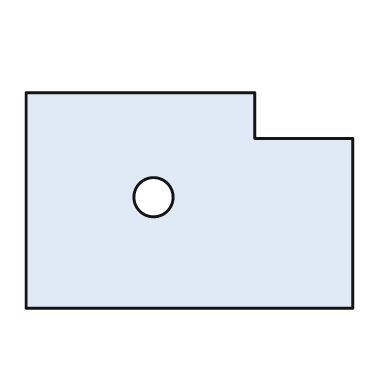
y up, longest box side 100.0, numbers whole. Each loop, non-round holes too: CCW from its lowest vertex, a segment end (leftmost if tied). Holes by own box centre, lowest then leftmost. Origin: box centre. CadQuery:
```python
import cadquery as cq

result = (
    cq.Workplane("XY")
    .moveTo(-50.0, -33.0)
    .lineTo(50.0, -33.0)
    .lineTo(50.0, 19.0)
    .lineTo(20.0, 19.0)
    .lineTo(20.0, 33.0)
    .lineTo(-50.0, 33.0)
    .close()
    .moveTo(-11.0, 1.0)
    .circle(6.0)
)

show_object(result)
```